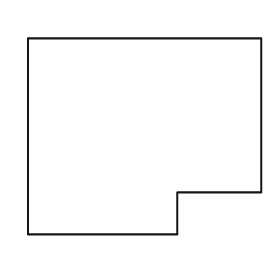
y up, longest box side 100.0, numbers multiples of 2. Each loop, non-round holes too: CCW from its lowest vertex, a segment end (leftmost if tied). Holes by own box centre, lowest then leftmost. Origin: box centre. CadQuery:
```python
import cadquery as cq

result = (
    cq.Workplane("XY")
    .moveTo(-50.0, -42.0)
    .lineTo(14.0, -42.0)
    .lineTo(14.0, -24.0)
    .lineTo(50.0, -24.0)
    .lineTo(50.0, 42.0)
    .lineTo(-50.0, 42.0)
    .close()
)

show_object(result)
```